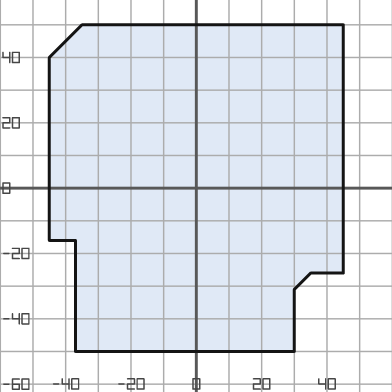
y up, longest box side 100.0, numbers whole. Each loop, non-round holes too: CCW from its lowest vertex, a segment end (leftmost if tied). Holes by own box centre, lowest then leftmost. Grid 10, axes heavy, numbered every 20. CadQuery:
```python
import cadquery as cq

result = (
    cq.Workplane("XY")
    .moveTo(-37.0, -50.0)
    .lineTo(30.0, -50.0)
    .lineTo(30.0, -31.0)
    .lineTo(35.0, -26.0)
    .lineTo(45.0, -26.0)
    .lineTo(45.0, 50.0)
    .lineTo(-35.0, 50.0)
    .lineTo(-45.0, 40.0)
    .lineTo(-45.0, -16.0)
    .lineTo(-37.0, -16.0)
    .close()
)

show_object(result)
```